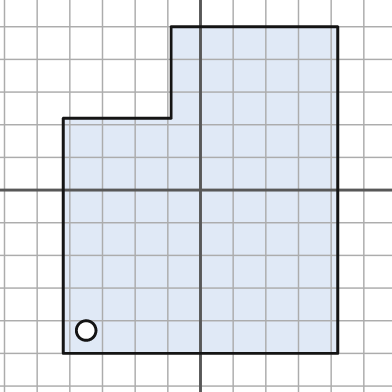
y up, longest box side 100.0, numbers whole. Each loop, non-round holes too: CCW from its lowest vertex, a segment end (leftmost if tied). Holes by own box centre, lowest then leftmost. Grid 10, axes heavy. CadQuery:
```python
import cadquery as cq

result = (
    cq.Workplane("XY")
    .moveTo(-42.0, -50.0)
    .lineTo(42.0, -50.0)
    .lineTo(42.0, 50.0)
    .lineTo(-9.0, 50.0)
    .lineTo(-9.0, 22.0)
    .lineTo(-42.0, 22.0)
    .close()
    .moveTo(-35.0, -43.0)
    .circle(3.0)
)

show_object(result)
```